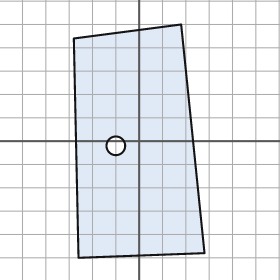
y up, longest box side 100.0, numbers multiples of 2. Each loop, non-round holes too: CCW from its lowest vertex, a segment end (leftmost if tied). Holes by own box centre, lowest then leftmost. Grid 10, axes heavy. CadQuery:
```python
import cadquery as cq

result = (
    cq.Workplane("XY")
    .moveTo(-26.0, -50.0)
    .lineTo(28.0, -48.0)
    .lineTo(18.0, 50.0)
    .lineTo(-28.0, 44.0)
    .close()
    .moveTo(-10.0, -2.0)
    .circle(4.0)
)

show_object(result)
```